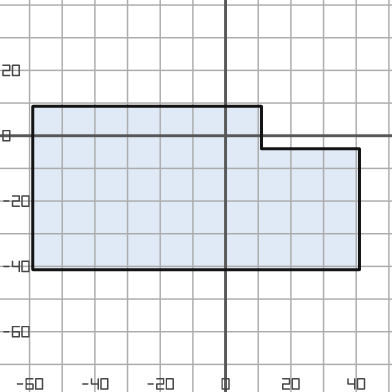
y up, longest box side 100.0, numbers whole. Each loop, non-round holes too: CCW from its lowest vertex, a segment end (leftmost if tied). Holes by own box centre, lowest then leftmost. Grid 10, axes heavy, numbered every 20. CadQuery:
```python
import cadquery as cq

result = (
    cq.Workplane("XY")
    .moveTo(-59.0, -41.0)
    .lineTo(41.0, -41.0)
    .lineTo(41.0, -4.0)
    .lineTo(11.0, -4.0)
    .lineTo(11.0, 9.0)
    .lineTo(-59.0, 9.0)
    .close()
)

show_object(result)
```